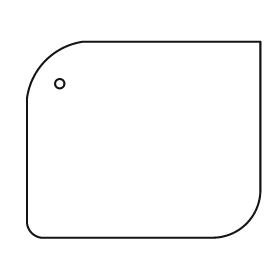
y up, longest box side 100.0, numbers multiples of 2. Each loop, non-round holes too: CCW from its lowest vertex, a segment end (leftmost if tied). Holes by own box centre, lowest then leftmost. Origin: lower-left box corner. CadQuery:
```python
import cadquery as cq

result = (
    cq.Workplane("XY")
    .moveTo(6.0, 0.0)
    .lineTo(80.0, 0.0)
    .threePointArc((94.0, 6.0), (100.0, 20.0))
    .lineTo(100.0, 84.0)
    .lineTo(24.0, 84.0)
    .threePointArc((8.0, 76.0), (0.0, 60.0))
    .lineTo(0.0, 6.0)
    .threePointArc((2.0, 2.0), (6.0, 0.0))
    .close()
    .moveTo(14.0, 66.0)
    .circle(2.0)
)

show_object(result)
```